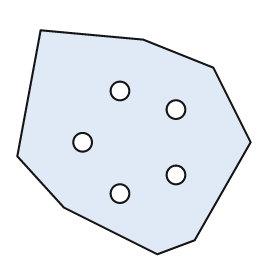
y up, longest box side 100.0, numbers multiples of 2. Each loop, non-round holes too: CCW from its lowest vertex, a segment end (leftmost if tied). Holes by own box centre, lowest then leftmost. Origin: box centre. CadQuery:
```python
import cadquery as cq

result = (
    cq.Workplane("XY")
    .moveTo(10.0, -48.0)
    .lineTo(26.0, -42.0)
    .lineTo(50.0, 0.0)
    .lineTo(34.0, 32.0)
    .lineTo(4.0, 44.0)
    .lineTo(-40.0, 48.0)
    .lineTo(-50.0, -6.0)
    .lineTo(-30.0, -28.0)
    .close()
    .moveTo(-6.0, -22.0)
    .circle(4.0)
    .moveTo(18.0, -14.0)
    .circle(4.0)
    .moveTo(-22.0, 0.0)
    .circle(4.0)
    .moveTo(18.0, 14.0)
    .circle(4.0)
    .moveTo(-6.0, 22.0)
    .circle(4.0)
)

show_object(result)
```